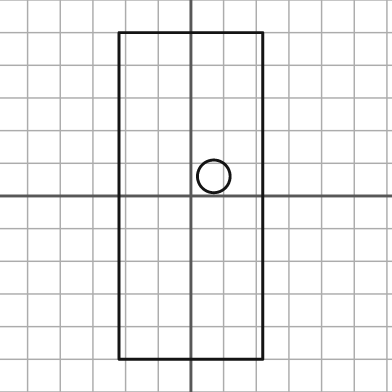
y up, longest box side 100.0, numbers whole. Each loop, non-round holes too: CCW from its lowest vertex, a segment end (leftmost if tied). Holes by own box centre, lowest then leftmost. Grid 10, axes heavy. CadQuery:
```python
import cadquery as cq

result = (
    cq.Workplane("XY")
    .moveTo(-22.0, -50.0)
    .lineTo(22.0, -50.0)
    .lineTo(22.0, 50.0)
    .lineTo(-22.0, 50.0)
    .close()
    .moveTo(7.0, 6.0)
    .circle(5.0)
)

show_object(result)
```